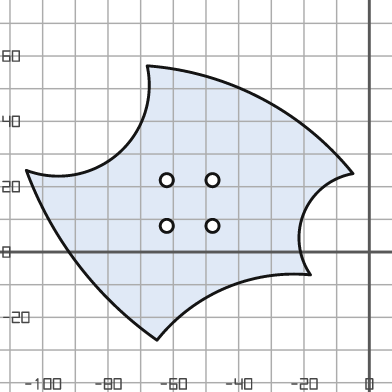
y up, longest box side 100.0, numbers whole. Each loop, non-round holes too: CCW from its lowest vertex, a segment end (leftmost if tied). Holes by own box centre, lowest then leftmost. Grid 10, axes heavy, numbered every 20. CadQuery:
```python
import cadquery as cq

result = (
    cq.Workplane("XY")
    .moveTo(-65.0, -27.0)
    .threePointArc((-44.0, -11.0), (-18.0, -7.0))
    .threePointArc((-20.0, 12.0), (-5.0, 24.0))
    .threePointArc((-33.0, 47.0), (-68.0, 57.0))
    .threePointArc((-77.0, 30.0), (-105.0, 25.0))
    .threePointArc((-89.0, -4.0), (-65.0, -27.0))
    .close()
    .moveTo(-62.0, 8.0)
    .circle(2.0)
    .moveTo(-48.0, 8.0)
    .circle(2.0)
    .moveTo(-62.0, 22.0)
    .circle(2.0)
    .moveTo(-48.0, 22.0)
    .circle(2.0)
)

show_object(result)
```